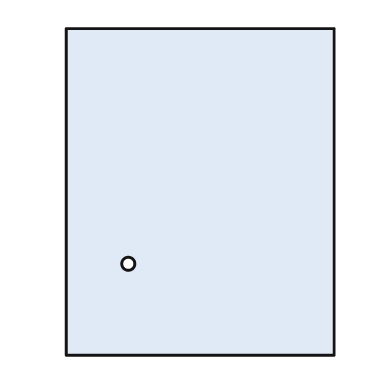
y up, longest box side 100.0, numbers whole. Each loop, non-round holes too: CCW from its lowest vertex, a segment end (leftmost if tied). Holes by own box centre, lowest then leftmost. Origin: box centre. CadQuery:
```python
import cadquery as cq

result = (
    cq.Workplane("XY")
    .moveTo(-41.0, -50.0)
    .lineTo(41.0, -50.0)
    .lineTo(41.0, 50.0)
    .lineTo(-41.0, 50.0)
    .close()
    .moveTo(-22.0, -22.0)
    .circle(2.0)
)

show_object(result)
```